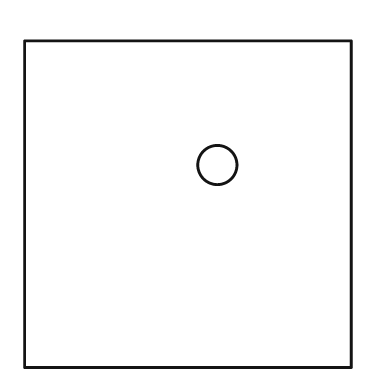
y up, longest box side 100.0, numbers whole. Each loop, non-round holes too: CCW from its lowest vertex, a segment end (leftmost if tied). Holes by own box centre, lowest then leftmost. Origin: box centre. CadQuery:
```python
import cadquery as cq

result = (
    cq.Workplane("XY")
    .moveTo(-50.0, -50.0)
    .lineTo(50.0, -50.0)
    .lineTo(50.0, 50.0)
    .lineTo(-50.0, 50.0)
    .close()
    .moveTo(9.0, 12.0)
    .circle(6.0)
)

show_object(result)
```